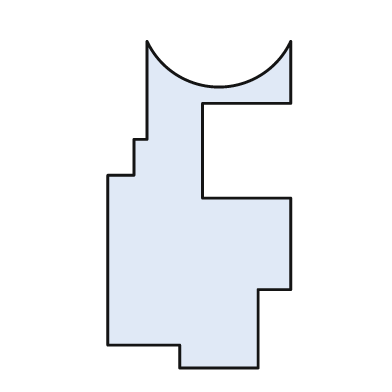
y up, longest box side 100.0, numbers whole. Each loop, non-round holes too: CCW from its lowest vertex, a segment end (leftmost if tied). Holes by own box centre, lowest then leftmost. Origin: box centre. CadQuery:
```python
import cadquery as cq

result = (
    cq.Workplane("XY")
    .moveTo(-6.0, -50.0)
    .lineTo(18.0, -50.0)
    .lineTo(18.0, -26.0)
    .lineTo(28.0, -26.0)
    .lineTo(28.0, 2.0)
    .lineTo(1.0, 2.0)
    .lineTo(1.0, 31.0)
    .lineTo(28.0, 31.0)
    .lineTo(28.0, 50.0)
    .threePointArc((6.0, 36.0), (-16.0, 50.0))
    .lineTo(-16.0, 20.0)
    .lineTo(-20.0, 20.0)
    .lineTo(-20.0, 9.0)
    .lineTo(-28.0, 9.0)
    .lineTo(-28.0, -43.0)
    .lineTo(-6.0, -43.0)
    .close()
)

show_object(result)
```